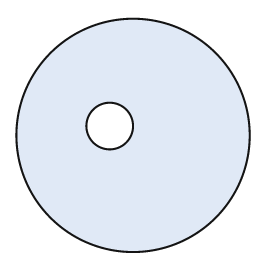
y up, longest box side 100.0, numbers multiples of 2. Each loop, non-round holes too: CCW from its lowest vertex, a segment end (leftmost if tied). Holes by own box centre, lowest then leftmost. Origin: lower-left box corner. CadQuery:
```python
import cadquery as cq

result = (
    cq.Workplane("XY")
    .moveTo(50.0, 50.0)
    .circle(50.0)
    .moveTo(40.0, 54.0)
    .circle(10.0)
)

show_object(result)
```